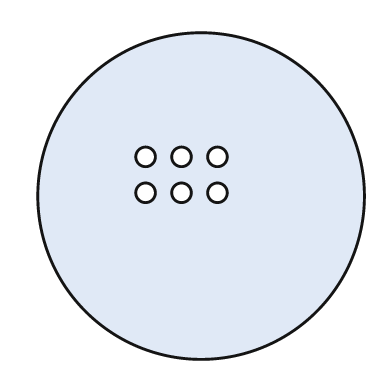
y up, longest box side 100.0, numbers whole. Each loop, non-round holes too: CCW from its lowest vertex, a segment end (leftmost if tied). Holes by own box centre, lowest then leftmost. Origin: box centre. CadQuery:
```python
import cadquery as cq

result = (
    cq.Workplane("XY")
    .moveTo(0.0, 0.0)
    .circle(50.0)
    .moveTo(-17.0, 1.0)
    .circle(3.0)
    .moveTo(-6.0, 1.0)
    .circle(3.0)
    .moveTo(5.0, 1.0)
    .circle(3.0)
    .moveTo(-17.0, 12.0)
    .circle(3.0)
    .moveTo(-6.0, 12.0)
    .circle(3.0)
    .moveTo(5.0, 12.0)
    .circle(3.0)
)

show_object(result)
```